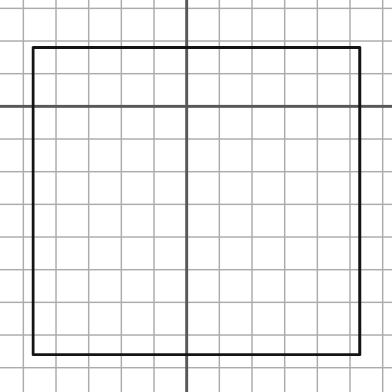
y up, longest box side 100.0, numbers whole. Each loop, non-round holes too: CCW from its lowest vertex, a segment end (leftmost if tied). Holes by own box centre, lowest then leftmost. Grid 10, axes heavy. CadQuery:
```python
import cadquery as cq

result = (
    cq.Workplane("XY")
    .moveTo(-47.0, -76.0)
    .lineTo(53.0, -76.0)
    .lineTo(53.0, 18.0)
    .lineTo(-47.0, 18.0)
    .close()
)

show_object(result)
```